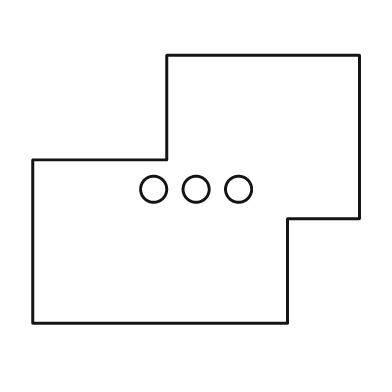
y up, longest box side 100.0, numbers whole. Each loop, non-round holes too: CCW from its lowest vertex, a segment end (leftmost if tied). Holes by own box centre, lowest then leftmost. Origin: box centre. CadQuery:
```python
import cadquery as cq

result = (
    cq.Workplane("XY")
    .moveTo(-50.0, -41.0)
    .lineTo(28.0, -41.0)
    .lineTo(28.0, -9.0)
    .lineTo(50.0, -9.0)
    .lineTo(50.0, 41.0)
    .lineTo(-9.0, 41.0)
    .lineTo(-9.0, 9.0)
    .lineTo(-50.0, 9.0)
    .close()
    .moveTo(-13.0, 0.0)
    .circle(4.0)
    .moveTo(0.0, 0.0)
    .circle(4.0)
    .moveTo(13.0, 0.0)
    .circle(4.0)
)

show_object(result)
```